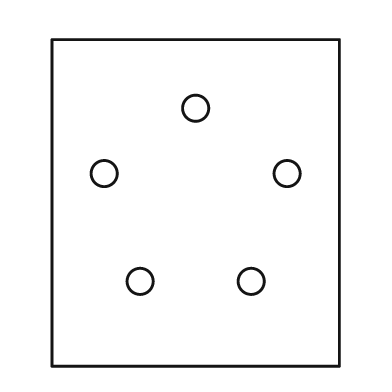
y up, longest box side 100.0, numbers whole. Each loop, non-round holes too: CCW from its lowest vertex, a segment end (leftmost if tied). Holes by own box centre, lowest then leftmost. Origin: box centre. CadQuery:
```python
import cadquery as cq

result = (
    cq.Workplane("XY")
    .moveTo(-44.0, -50.0)
    .lineTo(44.0, -50.0)
    .lineTo(44.0, 50.0)
    .lineTo(-44.0, 50.0)
    .close()
    .moveTo(-17.0, -24.0)
    .circle(4.0)
    .moveTo(17.0, -24.0)
    .circle(4.0)
    .moveTo(-28.0, 9.0)
    .circle(4.0)
    .moveTo(28.0, 9.0)
    .circle(4.0)
    .moveTo(0.0, 29.0)
    .circle(4.0)
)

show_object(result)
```